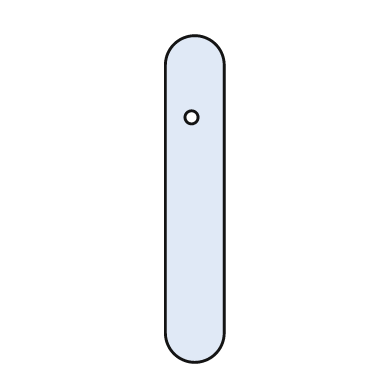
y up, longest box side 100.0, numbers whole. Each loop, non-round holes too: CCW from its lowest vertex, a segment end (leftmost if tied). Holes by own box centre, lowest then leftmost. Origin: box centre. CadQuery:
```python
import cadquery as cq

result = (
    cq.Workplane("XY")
    .moveTo(-9.0, -41.0)
    .threePointArc((0.0, -50.0), (9.0, -41.0))
    .lineTo(9.0, 41.0)
    .threePointArc((0.0, 50.0), (-9.0, 41.0))
    .close()
    .moveTo(-1.0, 25.0)
    .circle(2.0)
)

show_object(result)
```